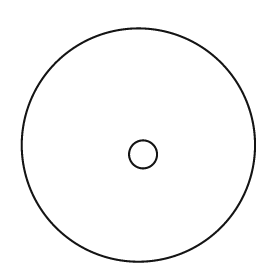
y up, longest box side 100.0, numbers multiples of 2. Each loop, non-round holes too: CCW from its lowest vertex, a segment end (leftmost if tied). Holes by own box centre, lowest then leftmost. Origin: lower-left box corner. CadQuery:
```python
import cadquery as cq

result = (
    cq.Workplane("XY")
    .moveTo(50.0, 50.0)
    .circle(50.0)
    .moveTo(52.0, 46.0)
    .circle(6.0)
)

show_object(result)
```